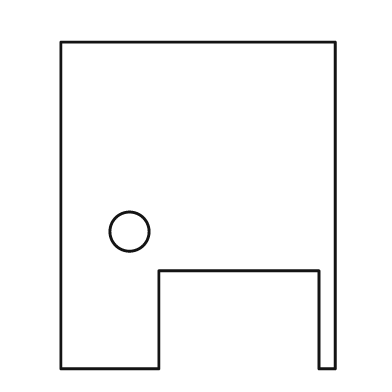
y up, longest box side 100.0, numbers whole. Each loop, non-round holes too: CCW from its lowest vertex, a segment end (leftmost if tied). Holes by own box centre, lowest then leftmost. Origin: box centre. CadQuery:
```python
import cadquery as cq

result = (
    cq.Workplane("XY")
    .moveTo(-42.0, -50.0)
    .lineTo(-12.0, -50.0)
    .lineTo(-12.0, -20.0)
    .lineTo(37.0, -20.0)
    .lineTo(37.0, -50.0)
    .lineTo(42.0, -50.0)
    .lineTo(42.0, 50.0)
    .lineTo(-42.0, 50.0)
    .close()
    .moveTo(-21.0, -8.0)
    .circle(6.0)
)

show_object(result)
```